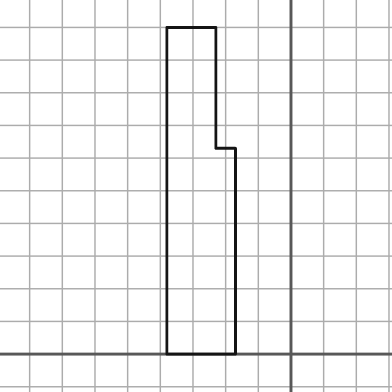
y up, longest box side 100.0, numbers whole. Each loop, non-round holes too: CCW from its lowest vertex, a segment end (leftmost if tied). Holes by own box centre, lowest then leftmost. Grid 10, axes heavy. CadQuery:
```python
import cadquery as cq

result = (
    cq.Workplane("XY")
    .moveTo(-38.0, 0.0)
    .lineTo(-17.0, 0.0)
    .lineTo(-17.0, 63.0)
    .lineTo(-23.0, 63.0)
    .lineTo(-23.0, 100.0)
    .lineTo(-38.0, 100.0)
    .close()
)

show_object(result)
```